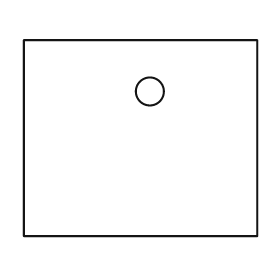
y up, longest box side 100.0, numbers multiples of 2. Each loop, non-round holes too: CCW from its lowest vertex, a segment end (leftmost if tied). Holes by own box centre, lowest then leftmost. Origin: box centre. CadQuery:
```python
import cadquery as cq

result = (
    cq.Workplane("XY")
    .moveTo(-50.0, -42.0)
    .lineTo(50.0, -42.0)
    .lineTo(50.0, 42.0)
    .lineTo(-50.0, 42.0)
    .close()
    .moveTo(4.0, 20.0)
    .circle(6.0)
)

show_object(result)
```